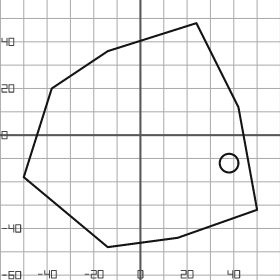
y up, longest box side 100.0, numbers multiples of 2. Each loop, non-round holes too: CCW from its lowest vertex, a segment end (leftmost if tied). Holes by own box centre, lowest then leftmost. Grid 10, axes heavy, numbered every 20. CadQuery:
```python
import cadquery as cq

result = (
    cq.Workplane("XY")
    .moveTo(-14.0, -48.0)
    .lineTo(16.0, -44.0)
    .lineTo(50.0, -32.0)
    .lineTo(42.0, 12.0)
    .lineTo(24.0, 48.0)
    .lineTo(-14.0, 36.0)
    .lineTo(-38.0, 20.0)
    .lineTo(-50.0, -18.0)
    .close()
    .moveTo(38.0, -12.0)
    .circle(4.0)
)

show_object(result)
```